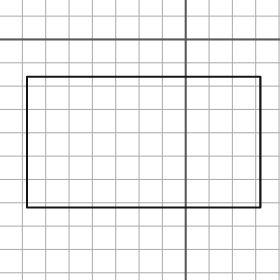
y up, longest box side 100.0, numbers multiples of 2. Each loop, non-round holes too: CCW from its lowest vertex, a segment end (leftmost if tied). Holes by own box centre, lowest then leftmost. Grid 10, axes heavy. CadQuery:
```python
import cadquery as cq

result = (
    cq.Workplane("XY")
    .moveTo(-68.0, -72.0)
    .lineTo(32.0, -72.0)
    .lineTo(32.0, -16.0)
    .lineTo(-68.0, -16.0)
    .close()
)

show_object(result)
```